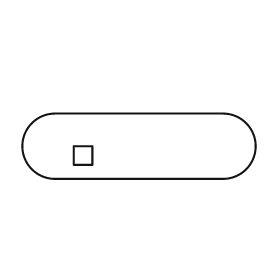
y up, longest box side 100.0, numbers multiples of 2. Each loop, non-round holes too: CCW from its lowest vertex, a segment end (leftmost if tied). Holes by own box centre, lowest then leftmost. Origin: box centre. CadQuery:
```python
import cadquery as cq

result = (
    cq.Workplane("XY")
    .moveTo(-36.0, -14.0)
    .lineTo(36.0, -14.0)
    .threePointArc((50.0, 0.0), (36.0, 14.0))
    .lineTo(-36.0, 14.0)
    .threePointArc((-50.0, 0.0), (-36.0, -14.0))
    .close()
    .moveTo(-28.0, -8.0)
    .lineTo(-20.0, -8.0)
    .lineTo(-20.0, 0.0)
    .lineTo(-28.0, 0.0)
    .close()
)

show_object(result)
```